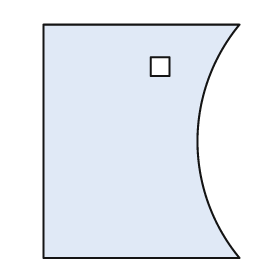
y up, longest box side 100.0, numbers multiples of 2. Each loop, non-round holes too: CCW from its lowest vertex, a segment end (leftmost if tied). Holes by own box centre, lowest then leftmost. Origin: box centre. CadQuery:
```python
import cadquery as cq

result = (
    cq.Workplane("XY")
    .moveTo(-42.0, -50.0)
    .lineTo(42.0, -50.0)
    .threePointArc((24.0, 0.0), (42.0, 50.0))
    .lineTo(-42.0, 50.0)
    .close()
    .moveTo(4.0, 28.0)
    .lineTo(12.0, 28.0)
    .lineTo(12.0, 36.0)
    .lineTo(4.0, 36.0)
    .close()
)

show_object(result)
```